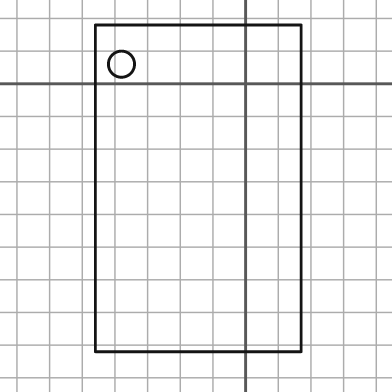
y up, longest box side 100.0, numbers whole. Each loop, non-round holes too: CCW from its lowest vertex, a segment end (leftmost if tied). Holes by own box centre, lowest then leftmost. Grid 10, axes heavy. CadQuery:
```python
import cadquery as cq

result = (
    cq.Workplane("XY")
    .moveTo(-46.0, -82.0)
    .lineTo(17.0, -82.0)
    .lineTo(17.0, 18.0)
    .lineTo(-46.0, 18.0)
    .close()
    .moveTo(-38.0, 6.0)
    .circle(4.0)
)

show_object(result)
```